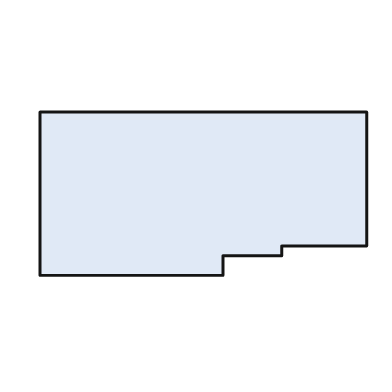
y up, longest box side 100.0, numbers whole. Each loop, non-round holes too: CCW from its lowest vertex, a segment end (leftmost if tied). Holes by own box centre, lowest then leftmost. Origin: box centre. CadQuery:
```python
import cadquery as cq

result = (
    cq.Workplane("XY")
    .moveTo(-50.0, -25.0)
    .lineTo(6.0, -25.0)
    .lineTo(6.0, -19.0)
    .lineTo(24.0, -19.0)
    .lineTo(24.0, -16.0)
    .lineTo(50.0, -16.0)
    .lineTo(50.0, 25.0)
    .lineTo(-50.0, 25.0)
    .close()
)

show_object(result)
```